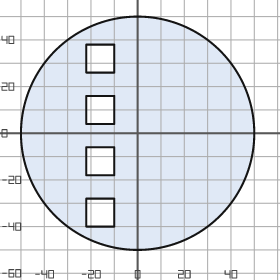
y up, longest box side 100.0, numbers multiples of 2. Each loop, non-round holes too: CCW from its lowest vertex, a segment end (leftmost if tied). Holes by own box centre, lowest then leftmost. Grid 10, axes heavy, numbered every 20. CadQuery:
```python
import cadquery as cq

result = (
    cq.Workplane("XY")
    .moveTo(0.0, 0.0)
    .circle(50.0)
    .moveTo(-22.0, -40.0)
    .lineTo(-10.0, -40.0)
    .lineTo(-10.0, -28.0)
    .lineTo(-22.0, -28.0)
    .close()
    .moveTo(-22.0, -18.0)
    .lineTo(-10.0, -18.0)
    .lineTo(-10.0, -6.0)
    .lineTo(-22.0, -6.0)
    .close()
    .moveTo(-22.0, 4.0)
    .lineTo(-10.0, 4.0)
    .lineTo(-10.0, 16.0)
    .lineTo(-22.0, 16.0)
    .close()
    .moveTo(-22.0, 26.0)
    .lineTo(-10.0, 26.0)
    .lineTo(-10.0, 38.0)
    .lineTo(-22.0, 38.0)
    .close()
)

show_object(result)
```